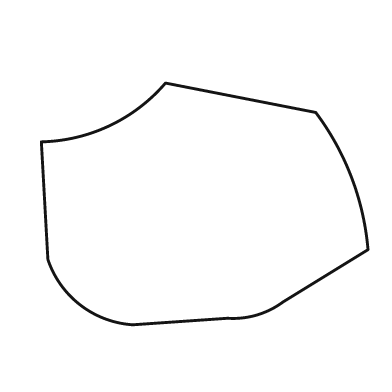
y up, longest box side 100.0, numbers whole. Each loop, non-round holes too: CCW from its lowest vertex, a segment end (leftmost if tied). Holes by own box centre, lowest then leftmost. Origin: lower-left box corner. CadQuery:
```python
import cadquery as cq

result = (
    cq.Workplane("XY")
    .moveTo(28.0, 0.0)
    .lineTo(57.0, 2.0)
    .threePointArc((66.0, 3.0), (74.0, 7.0))
    .lineTo(100.0, 23.0)
    .threePointArc((95.0, 45.0), (84.0, 65.0))
    .lineTo(38.0, 74.0)
    .threePointArc((21.0, 61.0), (0.0, 56.0))
    .lineTo(2.0, 20.0)
    .threePointArc((12.0, 6.0), (28.0, 0.0))
    .close()
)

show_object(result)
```